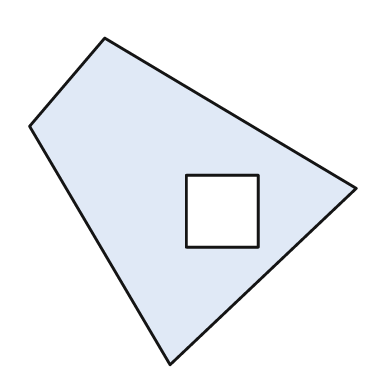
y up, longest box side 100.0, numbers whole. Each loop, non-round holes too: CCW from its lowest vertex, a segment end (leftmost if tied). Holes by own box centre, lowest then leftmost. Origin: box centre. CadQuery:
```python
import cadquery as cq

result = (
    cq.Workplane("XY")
    .moveTo(-7.0, -50.0)
    .lineTo(50.0, 4.0)
    .lineTo(-27.0, 50.0)
    .lineTo(-50.0, 23.0)
    .close()
    .moveTo(-2.0, -14.0)
    .lineTo(20.0, -14.0)
    .lineTo(20.0, 8.0)
    .lineTo(-2.0, 8.0)
    .close()
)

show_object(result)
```